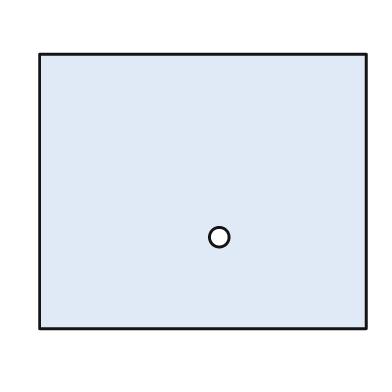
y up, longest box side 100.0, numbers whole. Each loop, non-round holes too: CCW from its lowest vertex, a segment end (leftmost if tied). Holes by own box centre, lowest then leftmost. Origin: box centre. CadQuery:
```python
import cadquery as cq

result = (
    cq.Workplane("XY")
    .moveTo(-50.0, -42.0)
    .lineTo(50.0, -42.0)
    .lineTo(50.0, 42.0)
    .lineTo(-50.0, 42.0)
    .close()
    .moveTo(5.0, -14.0)
    .circle(3.0)
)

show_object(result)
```